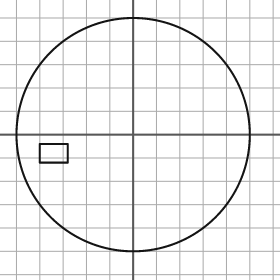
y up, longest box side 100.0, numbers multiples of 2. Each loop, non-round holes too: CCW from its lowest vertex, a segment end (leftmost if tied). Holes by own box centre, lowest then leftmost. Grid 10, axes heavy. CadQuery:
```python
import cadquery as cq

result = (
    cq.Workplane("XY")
    .moveTo(0.0, 0.0)
    .circle(50.0)
    .moveTo(-40.0, -12.0)
    .lineTo(-28.0, -12.0)
    .lineTo(-28.0, -4.0)
    .lineTo(-40.0, -4.0)
    .close()
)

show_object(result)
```